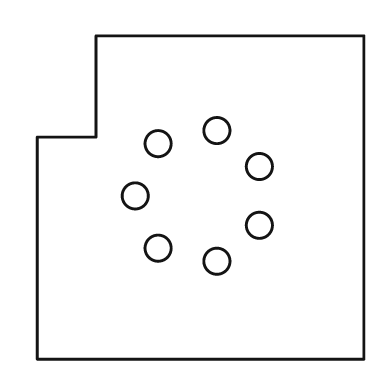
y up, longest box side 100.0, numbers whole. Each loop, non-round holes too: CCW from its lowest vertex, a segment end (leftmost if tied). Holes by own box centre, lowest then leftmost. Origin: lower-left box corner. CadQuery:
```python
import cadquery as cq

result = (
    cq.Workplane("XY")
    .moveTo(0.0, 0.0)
    .lineTo(100.0, 0.0)
    .lineTo(100.0, 99.0)
    .lineTo(18.0, 99.0)
    .lineTo(18.0, 68.0)
    .lineTo(0.0, 68.0)
    .close()
    .moveTo(55.0, 30.0)
    .circle(4.0)
    .moveTo(37.0, 34.0)
    .circle(4.0)
    .moveTo(68.0, 41.0)
    .circle(4.0)
    .moveTo(30.0, 50.0)
    .circle(4.0)
    .moveTo(68.0, 59.0)
    .circle(4.0)
    .moveTo(37.0, 66.0)
    .circle(4.0)
    .moveTo(55.0, 70.0)
    .circle(4.0)
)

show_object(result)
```